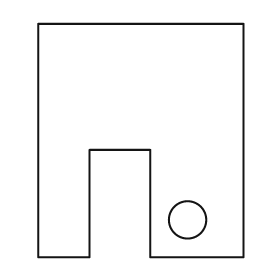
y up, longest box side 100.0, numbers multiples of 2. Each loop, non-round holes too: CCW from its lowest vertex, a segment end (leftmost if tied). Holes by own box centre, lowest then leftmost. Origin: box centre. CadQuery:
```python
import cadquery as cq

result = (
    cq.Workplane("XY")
    .moveTo(-44.0, -50.0)
    .lineTo(-22.0, -50.0)
    .lineTo(-22.0, -4.0)
    .lineTo(4.0, -4.0)
    .lineTo(4.0, -50.0)
    .lineTo(44.0, -50.0)
    .lineTo(44.0, 50.0)
    .lineTo(-44.0, 50.0)
    .close()
    .moveTo(20.0, -34.0)
    .circle(8.0)
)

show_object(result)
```